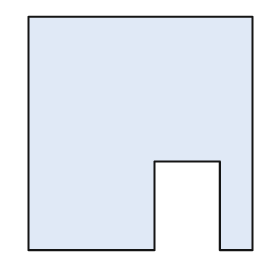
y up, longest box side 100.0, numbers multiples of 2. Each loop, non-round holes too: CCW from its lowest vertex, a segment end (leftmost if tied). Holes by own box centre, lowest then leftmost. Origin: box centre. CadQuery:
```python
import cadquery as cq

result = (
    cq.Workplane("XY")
    .moveTo(-48.0, -50.0)
    .lineTo(6.0, -50.0)
    .lineTo(6.0, -12.0)
    .lineTo(34.0, -12.0)
    .lineTo(34.0, -50.0)
    .lineTo(48.0, -50.0)
    .lineTo(48.0, 50.0)
    .lineTo(-48.0, 50.0)
    .close()
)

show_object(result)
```